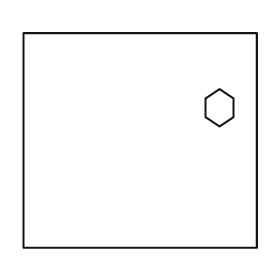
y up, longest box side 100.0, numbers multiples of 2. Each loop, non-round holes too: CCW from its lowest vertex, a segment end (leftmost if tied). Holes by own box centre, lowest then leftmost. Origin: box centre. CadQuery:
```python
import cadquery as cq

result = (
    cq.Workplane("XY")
    .moveTo(-50.0, -46.0)
    .lineTo(50.0, -46.0)
    .lineTo(50.0, 46.0)
    .lineTo(-50.0, 46.0)
    .close()
    .moveTo(34.0, 6.0)
    .lineTo(40.0, 10.0)
    .lineTo(40.0, 18.0)
    .lineTo(34.0, 22.0)
    .lineTo(28.0, 18.0)
    .lineTo(28.0, 10.0)
    .close()
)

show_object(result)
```